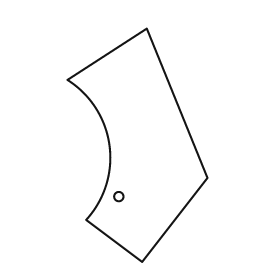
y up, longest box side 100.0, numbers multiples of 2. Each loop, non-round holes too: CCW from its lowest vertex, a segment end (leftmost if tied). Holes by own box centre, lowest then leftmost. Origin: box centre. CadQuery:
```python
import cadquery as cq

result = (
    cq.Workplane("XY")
    .moveTo(2.0, -50.0)
    .lineTo(30.0, -14.0)
    .lineTo(4.0, 50.0)
    .lineTo(-30.0, 28.0)
    .threePointArc((-12.0, 0.0), (-22.0, -32.0))
    .close()
    .moveTo(-8.0, -22.0)
    .circle(2.0)
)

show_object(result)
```